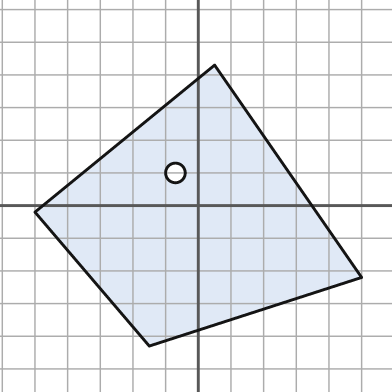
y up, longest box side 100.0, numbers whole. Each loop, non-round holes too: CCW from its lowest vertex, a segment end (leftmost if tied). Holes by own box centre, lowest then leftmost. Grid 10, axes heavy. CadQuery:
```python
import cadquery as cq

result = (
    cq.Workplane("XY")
    .moveTo(-15.0, -43.0)
    .lineTo(50.0, -22.0)
    .lineTo(5.0, 43.0)
    .lineTo(-50.0, -2.0)
    .close()
    .moveTo(-7.0, 10.0)
    .circle(3.0)
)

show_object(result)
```